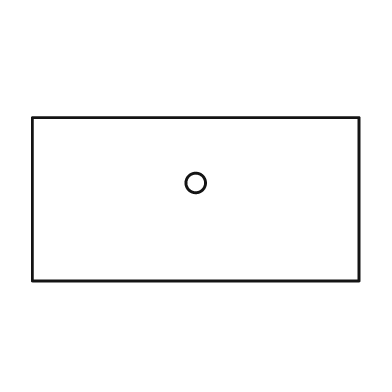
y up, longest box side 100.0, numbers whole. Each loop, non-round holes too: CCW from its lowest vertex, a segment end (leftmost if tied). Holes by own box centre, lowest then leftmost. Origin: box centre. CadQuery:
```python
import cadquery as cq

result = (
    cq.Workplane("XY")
    .moveTo(-50.0, -25.0)
    .lineTo(50.0, -25.0)
    .lineTo(50.0, 25.0)
    .lineTo(-50.0, 25.0)
    .close()
    .moveTo(0.0, 5.0)
    .circle(3.0)
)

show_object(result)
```